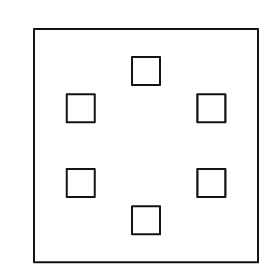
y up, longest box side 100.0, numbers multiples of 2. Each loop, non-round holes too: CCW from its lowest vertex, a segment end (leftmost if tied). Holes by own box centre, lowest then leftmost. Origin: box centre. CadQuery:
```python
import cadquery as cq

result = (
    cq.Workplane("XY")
    .moveTo(-48.0, -50.0)
    .lineTo(48.0, -50.0)
    .lineTo(48.0, 50.0)
    .lineTo(-48.0, 50.0)
    .close()
    .moveTo(-6.0, -38.0)
    .lineTo(6.0, -38.0)
    .lineTo(6.0, -26.0)
    .lineTo(-6.0, -26.0)
    .close()
    .moveTo(-34.0, -22.0)
    .lineTo(-22.0, -22.0)
    .lineTo(-22.0, -10.0)
    .lineTo(-34.0, -10.0)
    .close()
    .moveTo(22.0, -22.0)
    .lineTo(34.0, -22.0)
    .lineTo(34.0, -10.0)
    .lineTo(22.0, -10.0)
    .close()
    .moveTo(-34.0, 10.0)
    .lineTo(-22.0, 10.0)
    .lineTo(-22.0, 22.0)
    .lineTo(-34.0, 22.0)
    .close()
    .moveTo(22.0, 10.0)
    .lineTo(34.0, 10.0)
    .lineTo(34.0, 22.0)
    .lineTo(22.0, 22.0)
    .close()
    .moveTo(-6.0, 26.0)
    .lineTo(6.0, 26.0)
    .lineTo(6.0, 38.0)
    .lineTo(-6.0, 38.0)
    .close()
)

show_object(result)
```